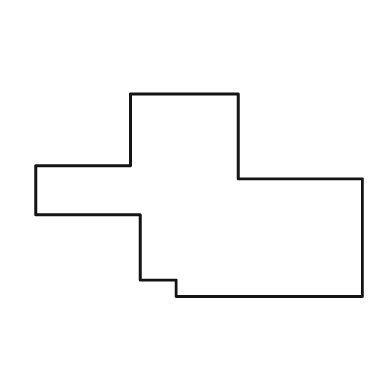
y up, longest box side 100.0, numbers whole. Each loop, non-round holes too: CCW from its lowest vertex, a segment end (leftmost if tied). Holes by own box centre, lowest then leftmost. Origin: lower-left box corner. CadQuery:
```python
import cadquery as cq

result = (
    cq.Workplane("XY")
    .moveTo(43.0, 0.0)
    .lineTo(100.0, 0.0)
    .lineTo(100.0, 36.0)
    .lineTo(62.0, 36.0)
    .lineTo(62.0, 62.0)
    .lineTo(29.0, 62.0)
    .lineTo(29.0, 40.0)
    .lineTo(0.0, 40.0)
    .lineTo(0.0, 25.0)
    .lineTo(32.0, 25.0)
    .lineTo(32.0, 5.0)
    .lineTo(43.0, 5.0)
    .close()
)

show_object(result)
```